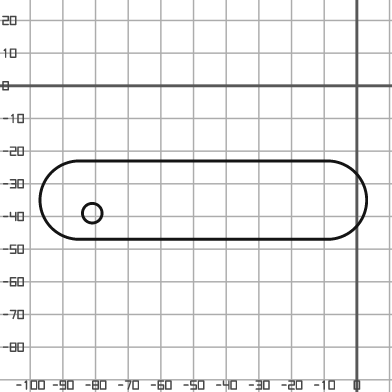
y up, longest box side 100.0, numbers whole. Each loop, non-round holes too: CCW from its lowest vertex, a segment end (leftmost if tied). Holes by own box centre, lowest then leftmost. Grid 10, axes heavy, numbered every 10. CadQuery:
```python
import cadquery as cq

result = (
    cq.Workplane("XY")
    .moveTo(-85.0, -47.0)
    .lineTo(-9.0, -47.0)
    .threePointArc((3.0, -35.0), (-9.0, -23.0))
    .lineTo(-85.0, -23.0)
    .threePointArc((-97.0, -35.0), (-85.0, -47.0))
    .close()
    .moveTo(-81.0, -39.0)
    .circle(3.0)
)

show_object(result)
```